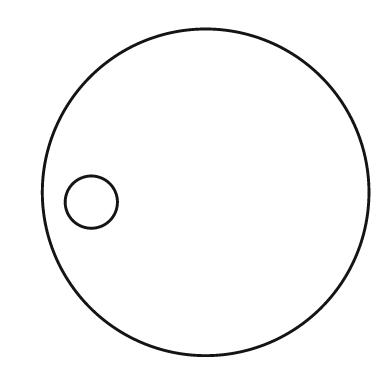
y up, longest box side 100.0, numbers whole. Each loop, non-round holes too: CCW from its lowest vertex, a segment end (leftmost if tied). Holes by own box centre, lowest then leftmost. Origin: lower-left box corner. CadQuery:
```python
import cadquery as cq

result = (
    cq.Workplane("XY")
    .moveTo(50.0, 50.0)
    .circle(50.0)
    .moveTo(15.0, 47.0)
    .circle(8.0)
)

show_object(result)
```